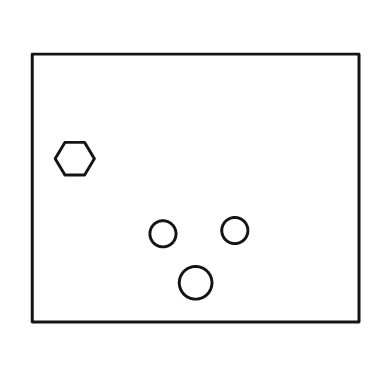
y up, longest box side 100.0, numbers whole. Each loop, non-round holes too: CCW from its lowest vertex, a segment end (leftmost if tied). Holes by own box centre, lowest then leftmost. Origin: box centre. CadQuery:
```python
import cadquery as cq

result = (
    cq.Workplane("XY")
    .moveTo(-50.0, -41.0)
    .lineTo(50.0, -41.0)
    .lineTo(50.0, 41.0)
    .lineTo(-50.0, 41.0)
    .close()
    .moveTo(0.0, -29.0)
    .circle(5.0)
    .moveTo(-10.0, -14.0)
    .circle(4.0)
    .moveTo(12.0, -13.0)
    .circle(4.0)
    .moveTo(-40.0, 4.0)
    .lineTo(-34.0, 4.0)
    .lineTo(-31.0, 9.0)
    .lineTo(-34.0, 14.0)
    .lineTo(-40.0, 14.0)
    .lineTo(-43.0, 9.0)
    .close()
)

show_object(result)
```